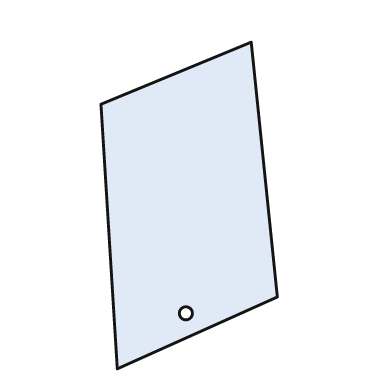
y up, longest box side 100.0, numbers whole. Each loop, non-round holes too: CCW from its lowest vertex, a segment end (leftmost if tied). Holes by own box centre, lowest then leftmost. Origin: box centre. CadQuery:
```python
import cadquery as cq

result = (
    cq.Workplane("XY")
    .moveTo(-22.0, -50.0)
    .lineTo(27.0, -28.0)
    .lineTo(19.0, 50.0)
    .lineTo(-27.0, 31.0)
    .close()
    .moveTo(-1.0, -33.0)
    .circle(2.0)
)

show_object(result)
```